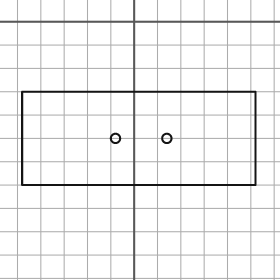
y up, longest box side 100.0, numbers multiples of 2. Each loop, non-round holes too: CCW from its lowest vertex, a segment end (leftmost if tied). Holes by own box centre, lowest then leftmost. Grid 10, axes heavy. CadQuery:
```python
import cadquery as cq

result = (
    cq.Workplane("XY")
    .moveTo(-48.0, -70.0)
    .lineTo(52.0, -70.0)
    .lineTo(52.0, -30.0)
    .lineTo(-48.0, -30.0)
    .close()
    .moveTo(-8.0, -50.0)
    .circle(2.0)
    .moveTo(14.0, -50.0)
    .circle(2.0)
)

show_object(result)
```